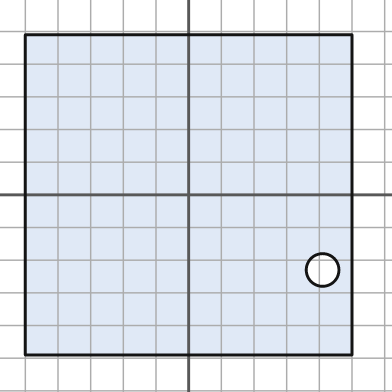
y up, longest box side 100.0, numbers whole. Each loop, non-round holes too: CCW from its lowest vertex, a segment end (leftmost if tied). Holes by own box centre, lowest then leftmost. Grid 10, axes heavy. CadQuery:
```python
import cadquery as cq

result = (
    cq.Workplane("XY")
    .moveTo(-50.0, -49.0)
    .lineTo(50.0, -49.0)
    .lineTo(50.0, 49.0)
    .lineTo(-50.0, 49.0)
    .close()
    .moveTo(41.0, -23.0)
    .circle(5.0)
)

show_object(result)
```